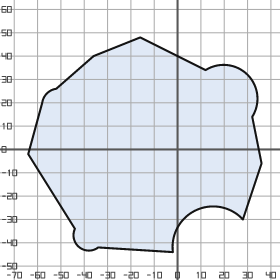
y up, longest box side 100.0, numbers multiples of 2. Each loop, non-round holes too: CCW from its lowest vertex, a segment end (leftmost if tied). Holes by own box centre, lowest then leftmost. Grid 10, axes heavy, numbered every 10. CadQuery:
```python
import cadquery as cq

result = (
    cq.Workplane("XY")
    .moveTo(-2.0, -44.0)
    .threePointArc((8.0, -26.0), (28.0, -30.0))
    .lineTo(36.0, -6.0)
    .lineTo(32.0, 14.0)
    .threePointArc((30.0, 32.0), (12.0, 34.0))
    .lineTo(-16.0, 48.0)
    .lineTo(-36.0, 40.0)
    .lineTo(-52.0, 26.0)
    .threePointArc((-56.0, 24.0), (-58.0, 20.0))
    .lineTo(-64.0, -2.0)
    .lineTo(-44.0, -34.0)
    .threePointArc((-42.0, -42.0), (-34.0, -42.0))
    .close()
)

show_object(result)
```